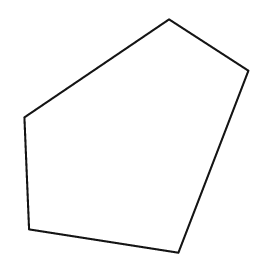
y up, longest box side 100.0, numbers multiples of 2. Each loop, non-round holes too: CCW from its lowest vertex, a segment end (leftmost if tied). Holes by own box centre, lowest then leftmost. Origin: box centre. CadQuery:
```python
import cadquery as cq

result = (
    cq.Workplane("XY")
    .moveTo(18.0, -50.0)
    .lineTo(48.0, 28.0)
    .lineTo(14.0, 50.0)
    .lineTo(-48.0, 8.0)
    .lineTo(-46.0, -40.0)
    .close()
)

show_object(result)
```